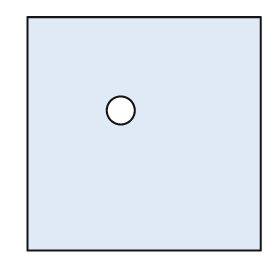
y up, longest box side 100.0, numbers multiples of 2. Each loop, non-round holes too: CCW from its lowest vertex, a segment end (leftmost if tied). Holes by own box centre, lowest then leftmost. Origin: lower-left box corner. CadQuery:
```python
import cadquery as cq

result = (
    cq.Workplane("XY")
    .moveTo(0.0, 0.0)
    .lineTo(100.0, 0.0)
    .lineTo(100.0, 100.0)
    .lineTo(0.0, 100.0)
    .close()
    .moveTo(40.0, 60.0)
    .circle(6.0)
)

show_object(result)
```